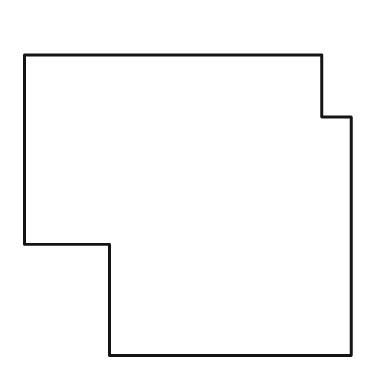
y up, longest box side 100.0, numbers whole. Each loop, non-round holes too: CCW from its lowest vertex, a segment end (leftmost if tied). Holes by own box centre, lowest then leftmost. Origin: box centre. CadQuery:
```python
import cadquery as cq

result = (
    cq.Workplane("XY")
    .moveTo(-24.0, -46.0)
    .lineTo(50.0, -46.0)
    .lineTo(50.0, 27.0)
    .lineTo(41.0, 27.0)
    .lineTo(41.0, 46.0)
    .lineTo(-50.0, 46.0)
    .lineTo(-50.0, -12.0)
    .lineTo(-24.0, -12.0)
    .close()
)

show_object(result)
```